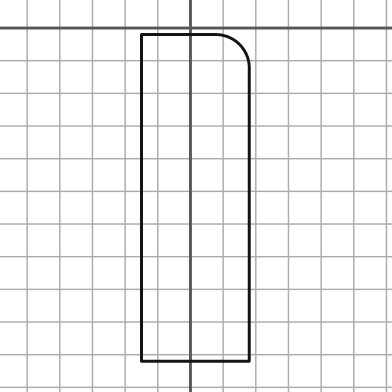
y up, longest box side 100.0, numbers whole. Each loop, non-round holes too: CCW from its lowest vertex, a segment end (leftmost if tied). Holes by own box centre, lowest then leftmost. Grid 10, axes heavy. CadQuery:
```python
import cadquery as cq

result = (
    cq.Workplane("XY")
    .moveTo(-15.0, -102.0)
    .lineTo(18.0, -102.0)
    .lineTo(18.0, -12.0)
    .threePointArc((15.0, -5.0), (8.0, -2.0))
    .lineTo(-15.0, -2.0)
    .close()
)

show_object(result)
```